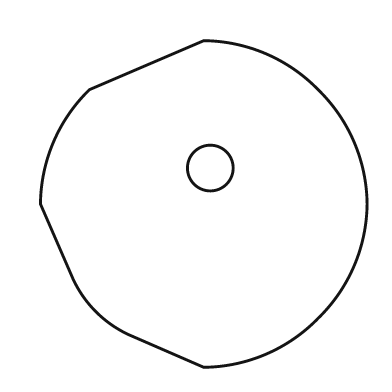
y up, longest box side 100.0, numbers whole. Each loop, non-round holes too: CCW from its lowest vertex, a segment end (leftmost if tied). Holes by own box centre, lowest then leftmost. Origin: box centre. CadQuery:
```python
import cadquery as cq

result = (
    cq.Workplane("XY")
    .moveTo(0.0, -50.0)
    .threePointArc((19.0, -46.0), (35.0, -35.0))
    .threePointArc((46.0, -19.0), (50.0, 0.0))
    .threePointArc((46.0, 19.0), (35.0, 35.0))
    .threePointArc((19.0, 46.0), (0.0, 50.0))
    .lineTo(-35.0, 35.0)
    .threePointArc((-46.0, 19.0), (-50.0, 0.0))
    .lineTo(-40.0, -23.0)
    .threePointArc((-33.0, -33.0), (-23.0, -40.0))
    .close()
    .moveTo(2.0, 11.0)
    .circle(7.0)
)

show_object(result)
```